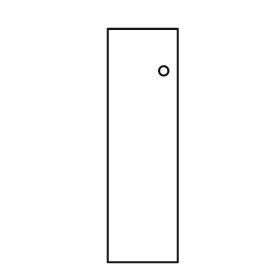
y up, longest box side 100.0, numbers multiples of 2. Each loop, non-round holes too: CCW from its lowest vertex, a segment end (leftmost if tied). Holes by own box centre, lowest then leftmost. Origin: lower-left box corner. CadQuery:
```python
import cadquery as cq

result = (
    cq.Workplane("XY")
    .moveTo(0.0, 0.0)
    .lineTo(30.0, 0.0)
    .lineTo(30.0, 100.0)
    .lineTo(0.0, 100.0)
    .close()
    .moveTo(24.0, 82.0)
    .circle(2.0)
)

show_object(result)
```